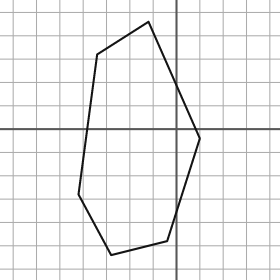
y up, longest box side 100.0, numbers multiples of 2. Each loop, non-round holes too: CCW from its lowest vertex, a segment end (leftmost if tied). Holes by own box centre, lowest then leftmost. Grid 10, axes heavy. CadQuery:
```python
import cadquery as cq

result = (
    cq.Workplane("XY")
    .moveTo(-28.0, -54.0)
    .lineTo(-4.0, -48.0)
    .lineTo(10.0, -4.0)
    .lineTo(-12.0, 46.0)
    .lineTo(-34.0, 32.0)
    .lineTo(-42.0, -28.0)
    .close()
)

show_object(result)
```